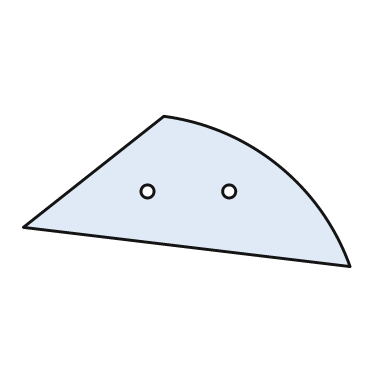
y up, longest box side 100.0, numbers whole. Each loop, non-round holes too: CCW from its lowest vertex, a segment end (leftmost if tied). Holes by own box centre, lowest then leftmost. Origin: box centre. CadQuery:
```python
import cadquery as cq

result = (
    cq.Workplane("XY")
    .moveTo(50.0, -23.0)
    .threePointArc((28.0, 8.0), (-7.0, 23.0))
    .lineTo(-50.0, -11.0)
    .close()
    .moveTo(-12.0, 0.0)
    .circle(2.0)
    .moveTo(13.0, 0.0)
    .circle(2.0)
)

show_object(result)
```